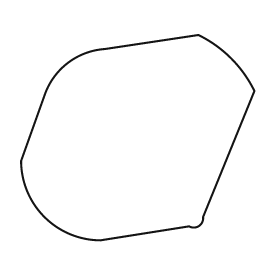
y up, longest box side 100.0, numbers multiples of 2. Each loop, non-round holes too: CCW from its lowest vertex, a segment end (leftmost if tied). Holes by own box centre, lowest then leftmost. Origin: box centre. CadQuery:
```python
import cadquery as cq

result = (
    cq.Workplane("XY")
    .moveTo(-16.0, -44.0)
    .lineTo(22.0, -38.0)
    .threePointArc((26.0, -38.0), (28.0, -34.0))
    .lineTo(50.0, 20.0)
    .threePointArc((40.0, 34.0), (26.0, 44.0))
    .lineTo(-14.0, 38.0)
    .threePointArc((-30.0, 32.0), (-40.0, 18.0))
    .lineTo(-50.0, -10.0)
    .threePointArc((-40.0, -34.0), (-16.0, -44.0))
    .close()
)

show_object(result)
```